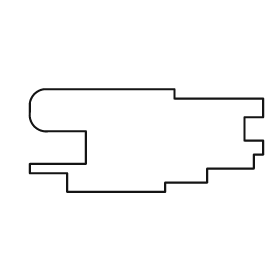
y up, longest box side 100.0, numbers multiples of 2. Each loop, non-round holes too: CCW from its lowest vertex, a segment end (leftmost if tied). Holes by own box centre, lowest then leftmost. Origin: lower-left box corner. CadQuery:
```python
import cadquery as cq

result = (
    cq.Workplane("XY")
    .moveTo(16.0, 0.0)
    .lineTo(58.0, 0.0)
    .lineTo(58.0, 4.0)
    .lineTo(76.0, 4.0)
    .lineTo(76.0, 10.0)
    .lineTo(96.0, 10.0)
    .lineTo(96.0, 16.0)
    .lineTo(100.0, 16.0)
    .lineTo(100.0, 22.0)
    .lineTo(92.0, 22.0)
    .lineTo(92.0, 32.0)
    .lineTo(100.0, 32.0)
    .lineTo(100.0, 40.0)
    .lineTo(62.0, 40.0)
    .lineTo(62.0, 44.0)
    .lineTo(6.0, 44.0)
    .threePointArc((2.0, 42.0), (0.0, 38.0))
    .lineTo(0.0, 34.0)
    .threePointArc((2.0, 28.0), (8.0, 26.0))
    .lineTo(24.0, 26.0)
    .lineTo(24.0, 12.0)
    .lineTo(0.0, 12.0)
    .lineTo(0.0, 8.0)
    .lineTo(16.0, 8.0)
    .close()
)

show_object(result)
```